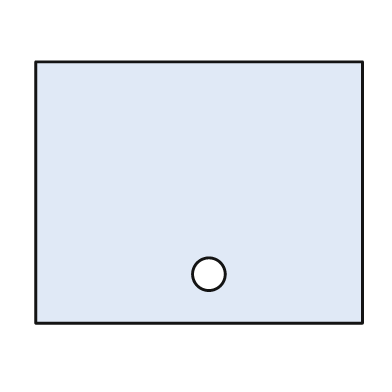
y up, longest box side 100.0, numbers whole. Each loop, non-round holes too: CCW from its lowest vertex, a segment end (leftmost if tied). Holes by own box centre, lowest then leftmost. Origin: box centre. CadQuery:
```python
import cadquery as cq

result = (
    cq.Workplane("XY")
    .moveTo(-50.0, -40.0)
    .lineTo(50.0, -40.0)
    .lineTo(50.0, 40.0)
    .lineTo(-50.0, 40.0)
    .close()
    .moveTo(3.0, -25.0)
    .circle(5.0)
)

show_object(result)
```